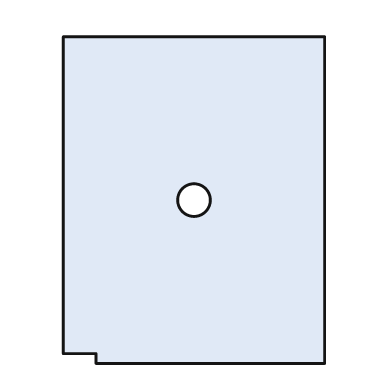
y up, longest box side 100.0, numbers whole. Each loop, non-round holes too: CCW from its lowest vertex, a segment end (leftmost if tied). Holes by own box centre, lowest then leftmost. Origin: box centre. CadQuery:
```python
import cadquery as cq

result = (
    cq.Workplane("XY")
    .moveTo(-30.0, -50.0)
    .lineTo(40.0, -50.0)
    .lineTo(40.0, 50.0)
    .lineTo(-40.0, 50.0)
    .lineTo(-40.0, -47.0)
    .lineTo(-30.0, -47.0)
    .close()
    .moveTo(0.0, 0.0)
    .circle(5.0)
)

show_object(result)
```